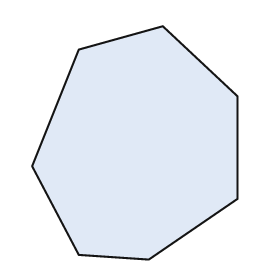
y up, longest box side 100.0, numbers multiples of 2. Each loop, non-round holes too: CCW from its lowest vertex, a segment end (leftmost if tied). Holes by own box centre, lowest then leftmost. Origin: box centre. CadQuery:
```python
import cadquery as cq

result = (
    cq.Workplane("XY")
    .moveTo(6.0, -50.0)
    .lineTo(44.0, -24.0)
    .lineTo(44.0, 20.0)
    .lineTo(12.0, 50.0)
    .lineTo(-24.0, 40.0)
    .lineTo(-44.0, -10.0)
    .lineTo(-24.0, -48.0)
    .close()
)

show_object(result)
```